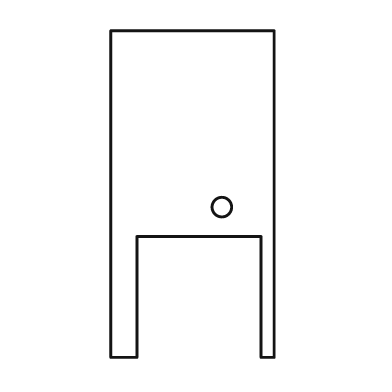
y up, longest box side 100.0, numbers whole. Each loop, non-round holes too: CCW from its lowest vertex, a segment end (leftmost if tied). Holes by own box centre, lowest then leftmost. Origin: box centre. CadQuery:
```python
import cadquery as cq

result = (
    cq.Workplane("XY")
    .moveTo(-25.0, -50.0)
    .lineTo(-17.0, -50.0)
    .lineTo(-17.0, -13.0)
    .lineTo(21.0, -13.0)
    .lineTo(21.0, -50.0)
    .lineTo(25.0, -50.0)
    .lineTo(25.0, 50.0)
    .lineTo(-25.0, 50.0)
    .close()
    .moveTo(9.0, -4.0)
    .circle(3.0)
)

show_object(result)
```